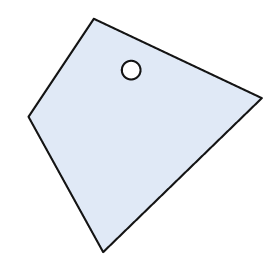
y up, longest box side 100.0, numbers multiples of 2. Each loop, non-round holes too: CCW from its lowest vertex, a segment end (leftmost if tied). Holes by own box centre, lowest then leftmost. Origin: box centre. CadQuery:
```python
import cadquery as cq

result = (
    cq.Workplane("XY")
    .moveTo(-18.0, -50.0)
    .lineTo(50.0, 16.0)
    .lineTo(-22.0, 50.0)
    .lineTo(-50.0, 8.0)
    .close()
    .moveTo(-6.0, 28.0)
    .circle(4.0)
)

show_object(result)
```